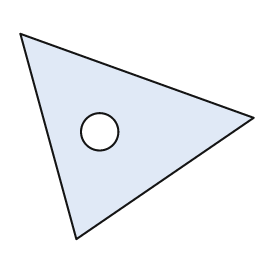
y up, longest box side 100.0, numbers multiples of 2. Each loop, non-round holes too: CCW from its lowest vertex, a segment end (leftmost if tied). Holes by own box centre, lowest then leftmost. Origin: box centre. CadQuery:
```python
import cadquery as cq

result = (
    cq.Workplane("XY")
    .moveTo(-26.0, -44.0)
    .lineTo(50.0, 8.0)
    .lineTo(-50.0, 44.0)
    .close()
    .moveTo(-16.0, 2.0)
    .circle(8.0)
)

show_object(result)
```